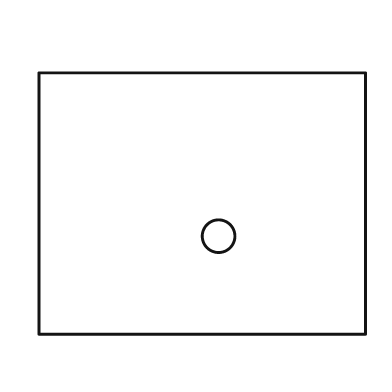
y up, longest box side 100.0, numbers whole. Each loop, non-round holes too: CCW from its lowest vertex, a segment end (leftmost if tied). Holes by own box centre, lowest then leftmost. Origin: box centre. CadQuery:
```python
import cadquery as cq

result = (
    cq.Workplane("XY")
    .moveTo(-50.0, -40.0)
    .lineTo(50.0, -40.0)
    .lineTo(50.0, 40.0)
    .lineTo(-50.0, 40.0)
    .close()
    .moveTo(5.0, -10.0)
    .circle(5.0)
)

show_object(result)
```